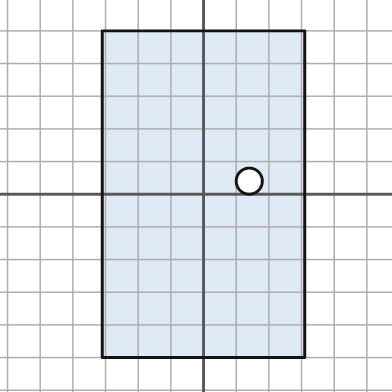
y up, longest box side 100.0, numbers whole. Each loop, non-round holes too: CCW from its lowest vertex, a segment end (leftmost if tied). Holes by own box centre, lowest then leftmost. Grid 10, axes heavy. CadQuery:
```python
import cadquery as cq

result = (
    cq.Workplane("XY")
    .moveTo(-31.0, -50.0)
    .lineTo(31.0, -50.0)
    .lineTo(31.0, 50.0)
    .lineTo(-31.0, 50.0)
    .close()
    .moveTo(14.0, 4.0)
    .circle(4.0)
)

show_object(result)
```